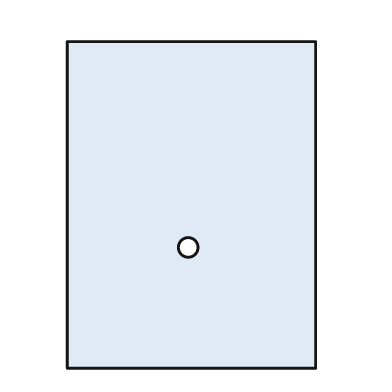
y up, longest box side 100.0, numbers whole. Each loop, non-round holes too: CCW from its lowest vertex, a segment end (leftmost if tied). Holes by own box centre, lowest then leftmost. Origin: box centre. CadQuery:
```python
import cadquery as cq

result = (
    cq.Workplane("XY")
    .moveTo(-38.0, -50.0)
    .lineTo(38.0, -50.0)
    .lineTo(38.0, 50.0)
    .lineTo(-38.0, 50.0)
    .close()
    .moveTo(-1.0, -13.0)
    .circle(3.0)
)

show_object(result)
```